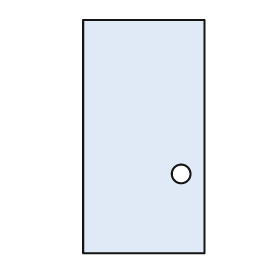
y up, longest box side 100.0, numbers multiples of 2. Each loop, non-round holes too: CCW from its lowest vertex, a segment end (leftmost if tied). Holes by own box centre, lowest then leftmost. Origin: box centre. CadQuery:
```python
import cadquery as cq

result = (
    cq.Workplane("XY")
    .moveTo(-26.0, -50.0)
    .lineTo(26.0, -50.0)
    .lineTo(26.0, 50.0)
    .lineTo(-26.0, 50.0)
    .close()
    .moveTo(16.0, -16.0)
    .circle(4.0)
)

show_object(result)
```